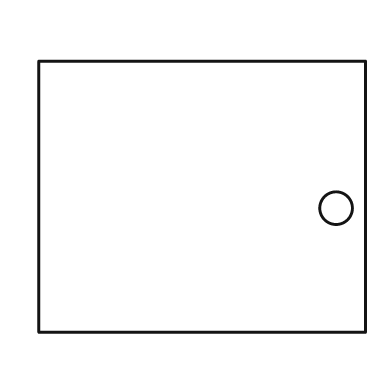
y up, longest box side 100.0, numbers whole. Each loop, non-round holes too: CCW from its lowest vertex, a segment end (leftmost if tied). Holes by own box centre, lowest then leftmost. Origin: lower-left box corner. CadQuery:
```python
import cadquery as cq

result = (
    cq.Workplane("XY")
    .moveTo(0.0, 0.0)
    .lineTo(100.0, 0.0)
    .lineTo(100.0, 83.0)
    .lineTo(0.0, 83.0)
    .close()
    .moveTo(91.0, 38.0)
    .circle(5.0)
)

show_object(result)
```